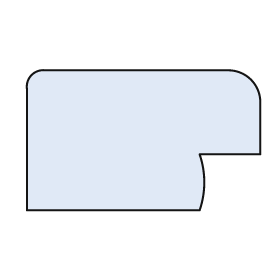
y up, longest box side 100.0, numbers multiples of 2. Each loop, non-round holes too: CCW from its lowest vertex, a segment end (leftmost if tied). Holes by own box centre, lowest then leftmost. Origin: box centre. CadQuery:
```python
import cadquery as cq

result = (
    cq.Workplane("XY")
    .moveTo(-50.0, -30.0)
    .lineTo(24.0, -30.0)
    .threePointArc((26.0, -18.0), (24.0, -6.0))
    .lineTo(50.0, -6.0)
    .lineTo(50.0, 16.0)
    .threePointArc((46.0, 26.0), (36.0, 30.0))
    .lineTo(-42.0, 30.0)
    .threePointArc((-48.0, 28.0), (-50.0, 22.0))
    .close()
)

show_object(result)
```